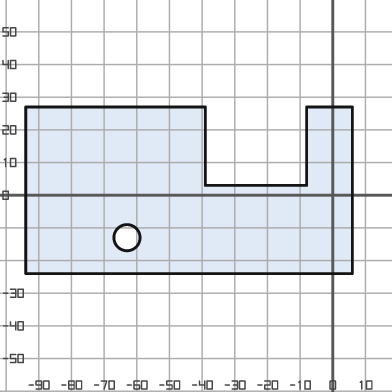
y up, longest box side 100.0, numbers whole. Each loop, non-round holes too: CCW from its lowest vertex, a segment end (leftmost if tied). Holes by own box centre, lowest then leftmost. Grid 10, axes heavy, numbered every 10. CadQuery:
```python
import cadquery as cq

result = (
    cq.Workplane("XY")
    .moveTo(-94.0, -24.0)
    .lineTo(6.0, -24.0)
    .lineTo(6.0, 27.0)
    .lineTo(-8.0, 27.0)
    .lineTo(-8.0, 3.0)
    .lineTo(-39.0, 3.0)
    .lineTo(-39.0, 27.0)
    .lineTo(-94.0, 27.0)
    .close()
    .moveTo(-63.0, -13.0)
    .circle(4.0)
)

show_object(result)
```